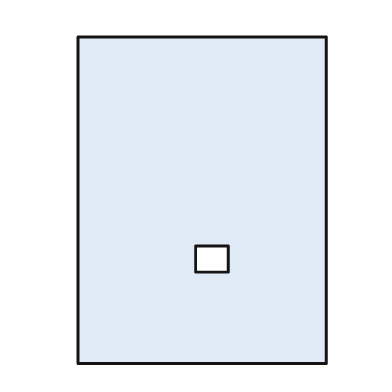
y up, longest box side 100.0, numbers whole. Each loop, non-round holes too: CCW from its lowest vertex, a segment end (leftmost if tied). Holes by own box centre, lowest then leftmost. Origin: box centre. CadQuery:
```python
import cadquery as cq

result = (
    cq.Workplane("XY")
    .moveTo(-38.0, -50.0)
    .lineTo(38.0, -50.0)
    .lineTo(38.0, 50.0)
    .lineTo(-38.0, 50.0)
    .close()
    .moveTo(-2.0, -22.0)
    .lineTo(8.0, -22.0)
    .lineTo(8.0, -14.0)
    .lineTo(-2.0, -14.0)
    .close()
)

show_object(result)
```